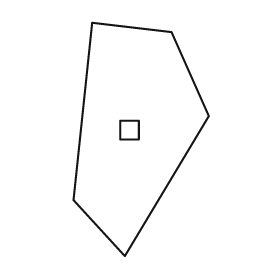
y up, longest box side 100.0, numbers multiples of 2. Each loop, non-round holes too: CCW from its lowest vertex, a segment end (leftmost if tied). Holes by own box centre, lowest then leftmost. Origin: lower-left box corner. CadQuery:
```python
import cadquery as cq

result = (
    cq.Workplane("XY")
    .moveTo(22.0, 0.0)
    .lineTo(58.0, 60.0)
    .lineTo(42.0, 96.0)
    .lineTo(8.0, 100.0)
    .lineTo(0.0, 24.0)
    .close()
    .moveTo(20.0, 50.0)
    .lineTo(28.0, 50.0)
    .lineTo(28.0, 58.0)
    .lineTo(20.0, 58.0)
    .close()
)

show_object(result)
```